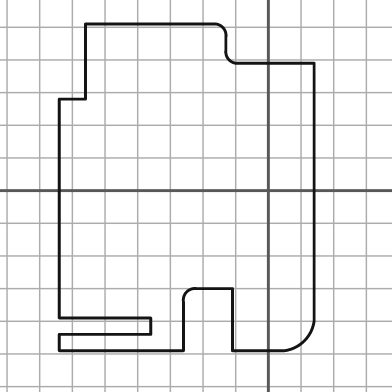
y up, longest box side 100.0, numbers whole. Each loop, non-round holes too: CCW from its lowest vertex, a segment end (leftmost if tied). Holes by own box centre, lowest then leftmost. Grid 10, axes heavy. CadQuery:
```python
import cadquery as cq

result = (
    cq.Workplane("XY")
    .moveTo(-64.0, -49.0)
    .lineTo(-26.0, -49.0)
    .lineTo(-26.0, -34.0)
    .threePointArc((-25.0, -31.0), (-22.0, -30.0))
    .lineTo(-11.0, -30.0)
    .lineTo(-11.0, -49.0)
    .lineTo(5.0, -49.0)
    .threePointArc((11.0, -46.0), (14.0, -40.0))
    .lineTo(14.0, 39.0)
    .lineTo(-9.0, 39.0)
    .threePointArc((-12.0, 40.0), (-13.0, 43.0))
    .lineTo(-13.0, 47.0)
    .threePointArc((-14.0, 50.0), (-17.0, 51.0))
    .lineTo(-56.0, 51.0)
    .lineTo(-56.0, 28.0)
    .lineTo(-64.0, 28.0)
    .lineTo(-64.0, -39.0)
    .lineTo(-36.0, -39.0)
    .lineTo(-36.0, -44.0)
    .lineTo(-64.0, -44.0)
    .close()
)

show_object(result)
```